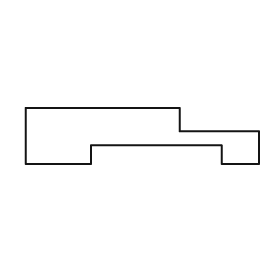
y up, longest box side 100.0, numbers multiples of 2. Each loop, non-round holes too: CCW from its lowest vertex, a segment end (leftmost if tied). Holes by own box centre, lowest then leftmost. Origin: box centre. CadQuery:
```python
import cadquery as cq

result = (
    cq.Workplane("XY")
    .moveTo(-50.0, -12.0)
    .lineTo(-22.0, -12.0)
    .lineTo(-22.0, -4.0)
    .lineTo(34.0, -4.0)
    .lineTo(34.0, -12.0)
    .lineTo(50.0, -12.0)
    .lineTo(50.0, 2.0)
    .lineTo(16.0, 2.0)
    .lineTo(16.0, 12.0)
    .lineTo(-50.0, 12.0)
    .close()
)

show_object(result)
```